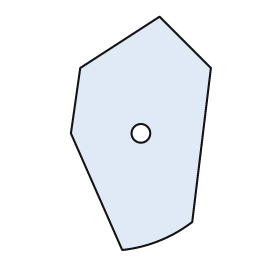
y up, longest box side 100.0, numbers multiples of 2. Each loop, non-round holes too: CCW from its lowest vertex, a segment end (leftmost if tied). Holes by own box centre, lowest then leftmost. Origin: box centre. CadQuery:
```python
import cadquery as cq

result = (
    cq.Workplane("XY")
    .moveTo(-8.0, -50.0)
    .threePointArc((8.0, -46.0), (22.0, -38.0))
    .lineTo(30.0, 28.0)
    .lineTo(8.0, 50.0)
    .lineTo(-26.0, 28.0)
    .lineTo(-30.0, 0.0)
    .close()
    .moveTo(0.0, 0.0)
    .circle(4.0)
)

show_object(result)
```